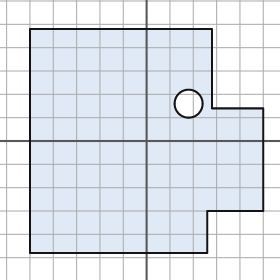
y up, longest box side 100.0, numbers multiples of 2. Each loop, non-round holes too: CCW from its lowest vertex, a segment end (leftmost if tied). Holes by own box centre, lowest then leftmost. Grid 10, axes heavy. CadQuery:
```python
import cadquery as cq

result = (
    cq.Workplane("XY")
    .moveTo(-50.0, -48.0)
    .lineTo(26.0, -48.0)
    .lineTo(26.0, -30.0)
    .lineTo(50.0, -30.0)
    .lineTo(50.0, 14.0)
    .lineTo(28.0, 14.0)
    .lineTo(28.0, 48.0)
    .lineTo(-50.0, 48.0)
    .close()
    .moveTo(18.0, 16.0)
    .circle(6.0)
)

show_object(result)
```